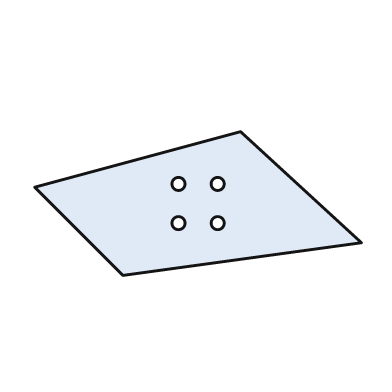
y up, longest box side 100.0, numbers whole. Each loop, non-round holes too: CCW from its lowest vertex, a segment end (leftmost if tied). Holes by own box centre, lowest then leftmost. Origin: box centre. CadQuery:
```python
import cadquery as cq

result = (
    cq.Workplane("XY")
    .moveTo(-23.0, -22.0)
    .lineTo(50.0, -12.0)
    .lineTo(13.0, 22.0)
    .lineTo(-50.0, 5.0)
    .close()
    .moveTo(-6.0, -6.0)
    .circle(2.0)
    .moveTo(6.0, -6.0)
    .circle(2.0)
    .moveTo(-6.0, 6.0)
    .circle(2.0)
    .moveTo(6.0, 6.0)
    .circle(2.0)
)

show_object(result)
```